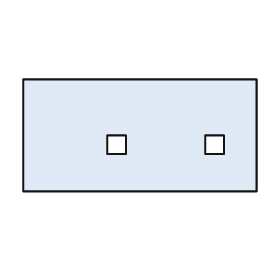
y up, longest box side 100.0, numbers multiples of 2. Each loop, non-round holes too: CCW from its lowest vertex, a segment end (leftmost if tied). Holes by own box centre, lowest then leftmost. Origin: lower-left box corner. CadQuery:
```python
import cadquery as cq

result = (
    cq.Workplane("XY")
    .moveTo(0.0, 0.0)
    .lineTo(100.0, 0.0)
    .lineTo(100.0, 48.0)
    .lineTo(0.0, 48.0)
    .close()
    .moveTo(36.0, 16.0)
    .lineTo(44.0, 16.0)
    .lineTo(44.0, 24.0)
    .lineTo(36.0, 24.0)
    .close()
    .moveTo(78.0, 16.0)
    .lineTo(86.0, 16.0)
    .lineTo(86.0, 24.0)
    .lineTo(78.0, 24.0)
    .close()
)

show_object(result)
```